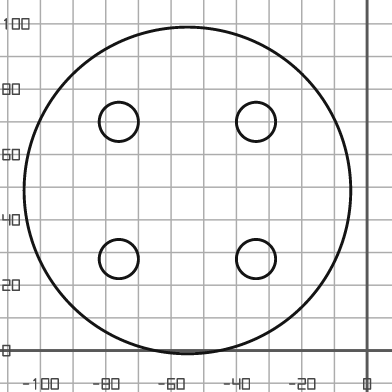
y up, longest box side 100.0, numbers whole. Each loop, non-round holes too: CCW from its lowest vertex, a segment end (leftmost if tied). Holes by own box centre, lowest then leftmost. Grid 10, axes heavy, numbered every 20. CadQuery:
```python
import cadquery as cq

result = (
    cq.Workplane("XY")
    .moveTo(-55.0, 49.0)
    .circle(50.0)
    .moveTo(-76.0, 28.0)
    .circle(6.0)
    .moveTo(-34.0, 28.0)
    .circle(6.0)
    .moveTo(-76.0, 70.0)
    .circle(6.0)
    .moveTo(-34.0, 70.0)
    .circle(6.0)
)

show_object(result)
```